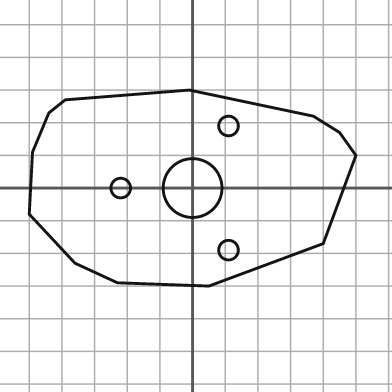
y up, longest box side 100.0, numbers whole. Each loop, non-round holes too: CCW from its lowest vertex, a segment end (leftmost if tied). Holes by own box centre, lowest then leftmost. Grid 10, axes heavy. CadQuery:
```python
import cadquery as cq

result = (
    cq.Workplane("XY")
    .moveTo(5.0, -30.0)
    .lineTo(40.0, -17.0)
    .lineTo(50.0, 10.0)
    .lineTo(45.0, 17.0)
    .lineTo(37.0, 22.0)
    .lineTo(-1.0, 30.0)
    .lineTo(-39.0, 27.0)
    .lineTo(-44.0, 23.0)
    .lineTo(-49.0, 11.0)
    .lineTo(-50.0, -8.0)
    .lineTo(-36.0, -23.0)
    .lineTo(-23.0, -29.0)
    .close()
    .moveTo(11.0, -19.0)
    .circle(3.0)
    .moveTo(-22.0, 0.0)
    .circle(3.0)
    .moveTo(0.0, 0.0)
    .circle(9.0)
    .moveTo(11.0, 19.0)
    .circle(3.0)
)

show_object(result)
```